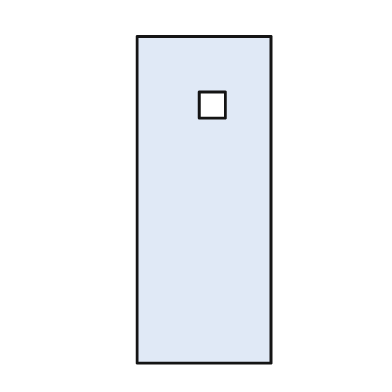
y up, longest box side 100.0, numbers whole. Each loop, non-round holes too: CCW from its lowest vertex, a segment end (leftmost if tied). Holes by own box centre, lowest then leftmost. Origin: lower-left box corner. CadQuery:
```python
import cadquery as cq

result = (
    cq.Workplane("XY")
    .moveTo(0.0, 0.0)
    .lineTo(41.0, 0.0)
    .lineTo(41.0, 100.0)
    .lineTo(0.0, 100.0)
    .close()
    .moveTo(19.0, 75.0)
    .lineTo(27.0, 75.0)
    .lineTo(27.0, 83.0)
    .lineTo(19.0, 83.0)
    .close()
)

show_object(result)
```